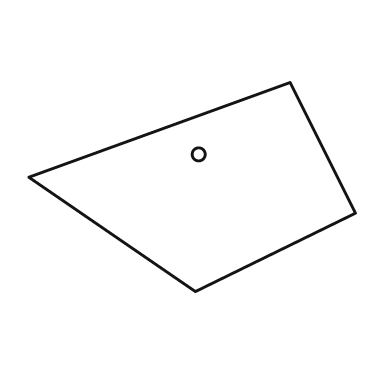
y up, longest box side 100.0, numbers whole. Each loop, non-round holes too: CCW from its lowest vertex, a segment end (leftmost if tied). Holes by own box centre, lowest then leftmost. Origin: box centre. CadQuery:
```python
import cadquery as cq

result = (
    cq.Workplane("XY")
    .moveTo(1.0, -32.0)
    .lineTo(50.0, -8.0)
    .lineTo(30.0, 32.0)
    .lineTo(-50.0, 3.0)
    .close()
    .moveTo(2.0, 10.0)
    .circle(2.0)
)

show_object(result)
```